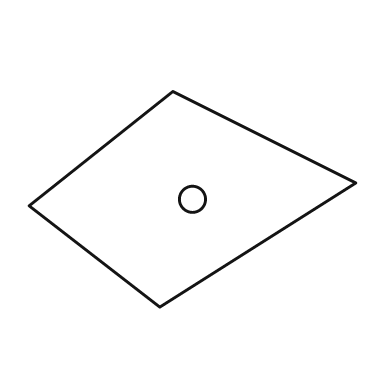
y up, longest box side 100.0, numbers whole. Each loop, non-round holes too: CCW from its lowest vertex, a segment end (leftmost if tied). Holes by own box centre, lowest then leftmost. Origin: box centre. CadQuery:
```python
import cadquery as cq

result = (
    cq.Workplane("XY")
    .moveTo(-10.0, -33.0)
    .lineTo(50.0, 5.0)
    .lineTo(-6.0, 33.0)
    .lineTo(-50.0, -2.0)
    .close()
    .moveTo(0.0, 0.0)
    .circle(4.0)
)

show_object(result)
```